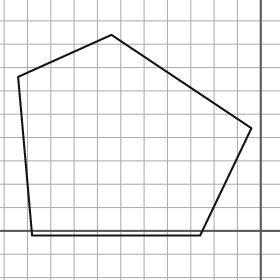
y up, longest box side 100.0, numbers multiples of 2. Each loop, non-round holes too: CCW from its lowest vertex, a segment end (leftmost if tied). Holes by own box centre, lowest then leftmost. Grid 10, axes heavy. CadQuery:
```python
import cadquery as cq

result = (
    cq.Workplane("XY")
    .moveTo(-98.0, -2.0)
    .lineTo(-26.0, -2.0)
    .lineTo(-4.0, 44.0)
    .lineTo(-64.0, 84.0)
    .lineTo(-104.0, 66.0)
    .close()
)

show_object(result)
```